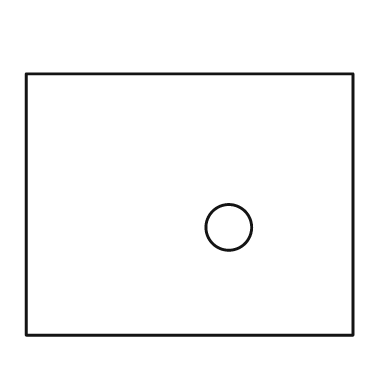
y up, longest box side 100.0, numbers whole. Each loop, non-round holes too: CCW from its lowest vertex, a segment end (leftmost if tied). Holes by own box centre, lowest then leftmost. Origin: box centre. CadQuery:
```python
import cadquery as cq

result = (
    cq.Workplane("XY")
    .moveTo(-50.0, -40.0)
    .lineTo(50.0, -40.0)
    .lineTo(50.0, 40.0)
    .lineTo(-50.0, 40.0)
    .close()
    .moveTo(12.0, -7.0)
    .circle(7.0)
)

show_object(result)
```